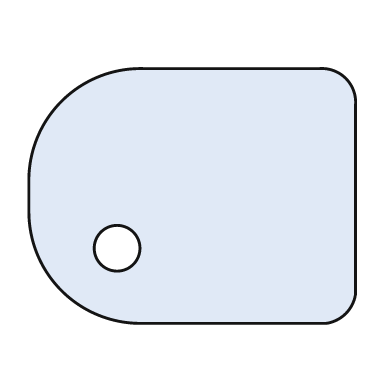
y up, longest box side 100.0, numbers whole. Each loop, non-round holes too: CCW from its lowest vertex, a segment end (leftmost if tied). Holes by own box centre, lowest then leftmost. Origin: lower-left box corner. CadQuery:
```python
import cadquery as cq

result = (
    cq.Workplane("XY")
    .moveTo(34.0, 0.0)
    .lineTo(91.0, 0.0)
    .threePointArc((97.0, 3.0), (100.0, 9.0))
    .lineTo(100.0, 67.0)
    .threePointArc((97.0, 75.0), (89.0, 78.0))
    .lineTo(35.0, 78.0)
    .threePointArc((10.0, 68.0), (0.0, 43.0))
    .lineTo(0.0, 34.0)
    .threePointArc((10.0, 10.0), (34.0, 0.0))
    .close()
    .moveTo(27.0, 23.0)
    .circle(7.0)
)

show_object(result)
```